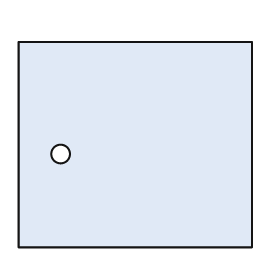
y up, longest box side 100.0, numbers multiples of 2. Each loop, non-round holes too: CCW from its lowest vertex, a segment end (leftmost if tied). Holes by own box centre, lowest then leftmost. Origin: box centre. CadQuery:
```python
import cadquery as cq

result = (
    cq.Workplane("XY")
    .moveTo(-50.0, -44.0)
    .lineTo(50.0, -44.0)
    .lineTo(50.0, 44.0)
    .lineTo(-50.0, 44.0)
    .close()
    .moveTo(-32.0, -4.0)
    .circle(4.0)
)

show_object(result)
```